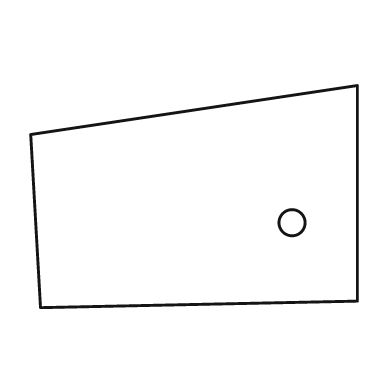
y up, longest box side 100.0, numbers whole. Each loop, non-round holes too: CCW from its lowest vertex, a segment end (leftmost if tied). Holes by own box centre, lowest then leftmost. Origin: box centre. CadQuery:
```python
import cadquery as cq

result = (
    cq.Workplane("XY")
    .moveTo(-47.0, -34.0)
    .lineTo(50.0, -32.0)
    .lineTo(50.0, 34.0)
    .lineTo(-50.0, 19.0)
    .close()
    .moveTo(30.0, -8.0)
    .circle(4.0)
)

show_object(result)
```